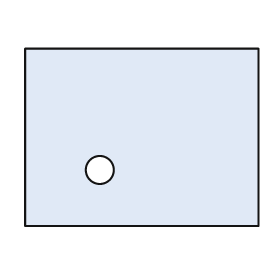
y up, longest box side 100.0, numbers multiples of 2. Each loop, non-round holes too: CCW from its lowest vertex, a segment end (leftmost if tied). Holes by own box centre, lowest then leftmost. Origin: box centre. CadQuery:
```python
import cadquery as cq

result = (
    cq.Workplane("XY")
    .moveTo(-50.0, -38.0)
    .lineTo(50.0, -38.0)
    .lineTo(50.0, 38.0)
    .lineTo(-50.0, 38.0)
    .close()
    .moveTo(-18.0, -14.0)
    .circle(6.0)
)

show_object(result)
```